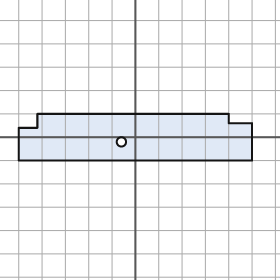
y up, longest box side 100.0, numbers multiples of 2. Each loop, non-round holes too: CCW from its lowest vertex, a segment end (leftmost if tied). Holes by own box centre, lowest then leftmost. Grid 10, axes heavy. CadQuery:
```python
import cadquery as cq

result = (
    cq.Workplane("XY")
    .moveTo(-50.0, -10.0)
    .lineTo(50.0, -10.0)
    .lineTo(50.0, 6.0)
    .lineTo(40.0, 6.0)
    .lineTo(40.0, 10.0)
    .lineTo(-42.0, 10.0)
    .lineTo(-42.0, 4.0)
    .lineTo(-50.0, 4.0)
    .close()
    .moveTo(-6.0, -2.0)
    .circle(2.0)
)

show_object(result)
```